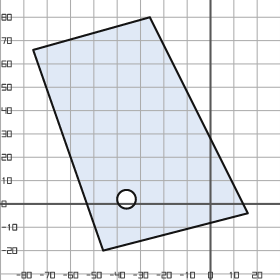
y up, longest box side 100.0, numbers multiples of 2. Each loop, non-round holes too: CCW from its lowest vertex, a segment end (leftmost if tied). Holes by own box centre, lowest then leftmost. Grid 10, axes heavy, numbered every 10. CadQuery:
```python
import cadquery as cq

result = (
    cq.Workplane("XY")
    .moveTo(-46.0, -20.0)
    .lineTo(16.0, -4.0)
    .lineTo(-26.0, 80.0)
    .lineTo(-76.0, 66.0)
    .close()
    .moveTo(-36.0, 2.0)
    .circle(4.0)
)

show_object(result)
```